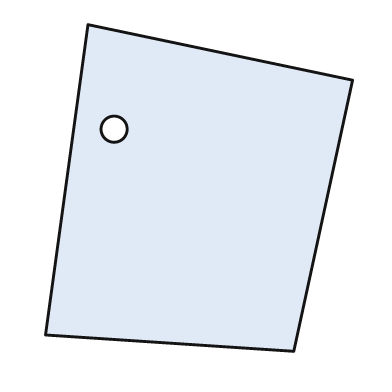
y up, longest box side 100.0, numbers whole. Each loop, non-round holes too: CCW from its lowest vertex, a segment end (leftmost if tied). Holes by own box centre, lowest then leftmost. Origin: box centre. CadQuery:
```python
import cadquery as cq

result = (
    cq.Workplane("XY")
    .moveTo(29.0, -50.0)
    .lineTo(47.0, 33.0)
    .lineTo(-34.0, 50.0)
    .lineTo(-47.0, -45.0)
    .close()
    .moveTo(-26.0, 18.0)
    .circle(4.0)
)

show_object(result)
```